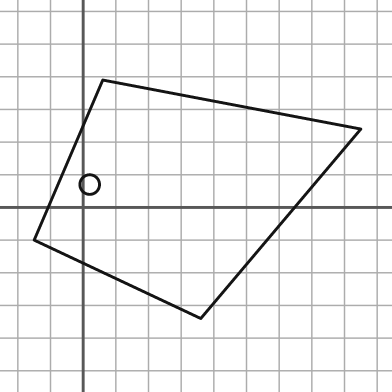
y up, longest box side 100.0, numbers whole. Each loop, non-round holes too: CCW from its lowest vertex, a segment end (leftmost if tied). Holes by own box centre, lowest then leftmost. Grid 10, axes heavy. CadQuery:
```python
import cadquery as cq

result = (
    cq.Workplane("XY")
    .moveTo(36.0, -34.0)
    .lineTo(85.0, 24.0)
    .lineTo(6.0, 39.0)
    .lineTo(-15.0, -10.0)
    .close()
    .moveTo(2.0, 7.0)
    .circle(3.0)
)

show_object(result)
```